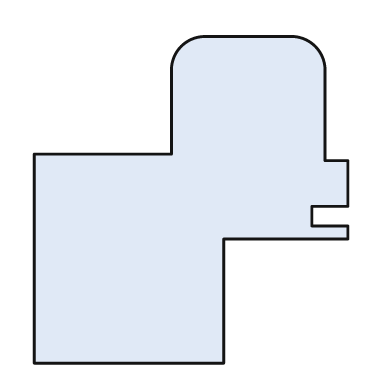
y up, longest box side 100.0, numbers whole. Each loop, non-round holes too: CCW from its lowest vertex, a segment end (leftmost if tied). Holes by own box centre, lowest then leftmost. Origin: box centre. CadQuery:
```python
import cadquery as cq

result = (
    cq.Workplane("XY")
    .moveTo(-48.0, -50.0)
    .lineTo(10.0, -50.0)
    .lineTo(10.0, -12.0)
    .lineTo(48.0, -12.0)
    .lineTo(48.0, -8.0)
    .lineTo(37.0, -8.0)
    .lineTo(37.0, -2.0)
    .lineTo(48.0, -2.0)
    .lineTo(48.0, 12.0)
    .lineTo(41.0, 12.0)
    .lineTo(41.0, 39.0)
    .threePointArc((38.0, 47.0), (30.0, 50.0))
    .lineTo(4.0, 50.0)
    .threePointArc((-3.0, 47.0), (-6.0, 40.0))
    .lineTo(-6.0, 14.0)
    .lineTo(-48.0, 14.0)
    .close()
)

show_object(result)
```